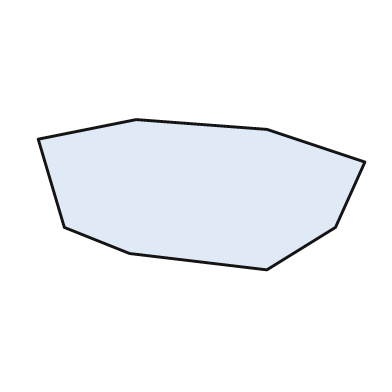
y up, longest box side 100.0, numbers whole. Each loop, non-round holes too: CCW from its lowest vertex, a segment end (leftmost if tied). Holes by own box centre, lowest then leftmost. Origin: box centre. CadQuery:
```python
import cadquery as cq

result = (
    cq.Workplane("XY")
    .moveTo(20.0, -23.0)
    .lineTo(41.0, -10.0)
    .lineTo(50.0, 10.0)
    .lineTo(20.0, 20.0)
    .lineTo(-20.0, 23.0)
    .lineTo(-50.0, 17.0)
    .lineTo(-42.0, -10.0)
    .lineTo(-22.0, -18.0)
    .close()
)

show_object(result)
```